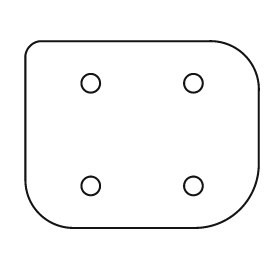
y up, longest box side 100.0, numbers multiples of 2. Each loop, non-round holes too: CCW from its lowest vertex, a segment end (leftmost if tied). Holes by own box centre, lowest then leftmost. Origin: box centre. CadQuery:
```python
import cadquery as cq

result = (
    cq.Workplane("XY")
    .moveTo(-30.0, -40.0)
    .lineTo(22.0, -40.0)
    .threePointArc((42.0, -32.0), (50.0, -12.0))
    .lineTo(50.0, 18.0)
    .threePointArc((44.0, 34.0), (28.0, 40.0))
    .lineTo(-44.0, 40.0)
    .threePointArc((-48.0, 38.0), (-50.0, 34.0))
    .lineTo(-50.0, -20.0)
    .threePointArc((-44.0, -34.0), (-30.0, -40.0))
    .close()
    .moveTo(-22.0, -22.0)
    .circle(4.0)
    .moveTo(22.0, -22.0)
    .circle(4.0)
    .moveTo(-22.0, 22.0)
    .circle(4.0)
    .moveTo(22.0, 22.0)
    .circle(4.0)
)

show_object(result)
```